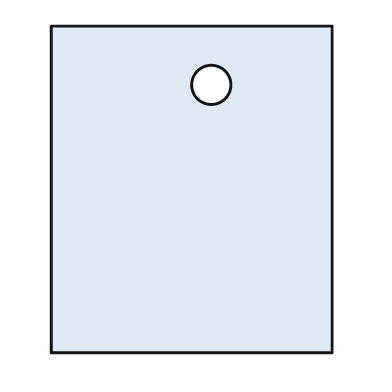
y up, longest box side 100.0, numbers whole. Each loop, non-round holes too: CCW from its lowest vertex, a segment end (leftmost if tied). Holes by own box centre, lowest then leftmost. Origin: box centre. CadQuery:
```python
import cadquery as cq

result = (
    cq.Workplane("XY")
    .moveTo(-43.0, -50.0)
    .lineTo(43.0, -50.0)
    .lineTo(43.0, 50.0)
    .lineTo(-43.0, 50.0)
    .close()
    .moveTo(6.0, 32.0)
    .circle(6.0)
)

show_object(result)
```